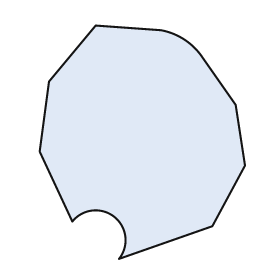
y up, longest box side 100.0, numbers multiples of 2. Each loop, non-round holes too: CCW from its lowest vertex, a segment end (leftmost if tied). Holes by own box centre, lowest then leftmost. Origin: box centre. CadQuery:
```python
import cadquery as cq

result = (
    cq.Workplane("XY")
    .moveTo(-10.0, -50.0)
    .lineTo(30.0, -36.0)
    .lineTo(44.0, -10.0)
    .lineTo(40.0, 16.0)
    .lineTo(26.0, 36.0)
    .threePointArc((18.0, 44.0), (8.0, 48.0))
    .lineTo(-20.0, 50.0)
    .lineTo(-40.0, 26.0)
    .lineTo(-44.0, -4.0)
    .lineTo(-30.0, -34.0)
    .threePointArc((-12.0, -32.0), (-10.0, -50.0))
    .close()
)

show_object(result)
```